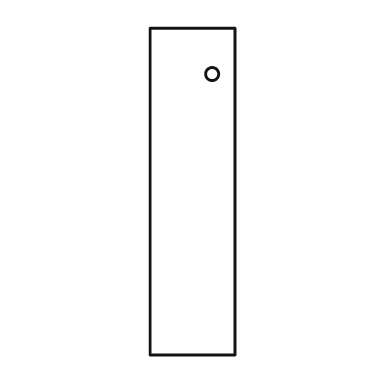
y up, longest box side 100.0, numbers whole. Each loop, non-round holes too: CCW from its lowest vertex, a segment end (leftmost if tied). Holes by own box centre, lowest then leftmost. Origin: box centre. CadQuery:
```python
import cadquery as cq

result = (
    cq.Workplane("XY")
    .moveTo(-13.0, -50.0)
    .lineTo(13.0, -50.0)
    .lineTo(13.0, 50.0)
    .lineTo(-13.0, 50.0)
    .close()
    .moveTo(6.0, 36.0)
    .circle(2.0)
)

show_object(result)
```